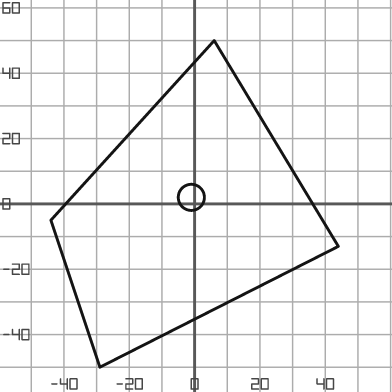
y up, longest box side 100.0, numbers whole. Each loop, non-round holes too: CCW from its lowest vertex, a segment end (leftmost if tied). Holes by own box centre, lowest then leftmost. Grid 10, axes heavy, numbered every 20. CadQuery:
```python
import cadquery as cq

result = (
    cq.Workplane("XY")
    .moveTo(-29.0, -50.0)
    .lineTo(44.0, -13.0)
    .lineTo(6.0, 50.0)
    .lineTo(-44.0, -5.0)
    .close()
    .moveTo(-1.0, 2.0)
    .circle(4.0)
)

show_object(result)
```